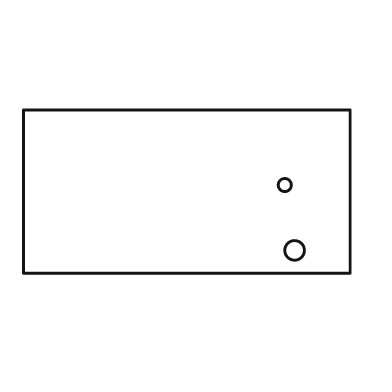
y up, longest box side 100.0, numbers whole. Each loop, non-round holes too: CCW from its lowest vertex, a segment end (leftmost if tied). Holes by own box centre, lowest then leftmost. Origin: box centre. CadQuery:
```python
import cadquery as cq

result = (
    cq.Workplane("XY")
    .moveTo(-50.0, -25.0)
    .lineTo(50.0, -25.0)
    .lineTo(50.0, 25.0)
    .lineTo(-50.0, 25.0)
    .close()
    .moveTo(33.0, -18.0)
    .circle(3.0)
    .moveTo(30.0, 2.0)
    .circle(2.0)
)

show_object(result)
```